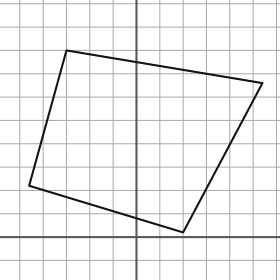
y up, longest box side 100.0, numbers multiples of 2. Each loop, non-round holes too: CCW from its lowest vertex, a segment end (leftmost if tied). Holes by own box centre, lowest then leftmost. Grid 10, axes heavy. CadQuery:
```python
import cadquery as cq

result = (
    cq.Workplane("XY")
    .moveTo(20.0, 2.0)
    .lineTo(54.0, 66.0)
    .lineTo(-30.0, 80.0)
    .lineTo(-46.0, 22.0)
    .close()
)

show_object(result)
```